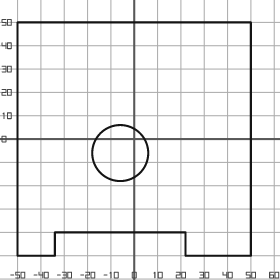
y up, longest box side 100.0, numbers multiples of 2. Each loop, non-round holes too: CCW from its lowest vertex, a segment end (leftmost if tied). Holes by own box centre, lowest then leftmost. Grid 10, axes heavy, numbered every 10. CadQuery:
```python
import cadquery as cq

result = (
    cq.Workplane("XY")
    .moveTo(-50.0, -50.0)
    .lineTo(-34.0, -50.0)
    .lineTo(-34.0, -40.0)
    .lineTo(22.0, -40.0)
    .lineTo(22.0, -50.0)
    .lineTo(50.0, -50.0)
    .lineTo(50.0, 50.0)
    .lineTo(-50.0, 50.0)
    .close()
    .moveTo(-6.0, -6.0)
    .circle(12.0)
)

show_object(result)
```